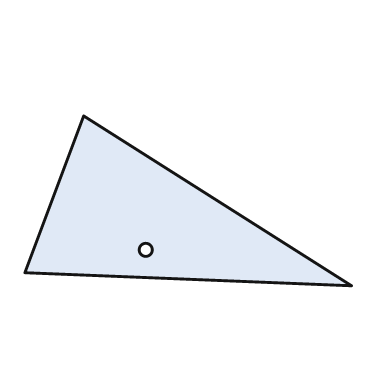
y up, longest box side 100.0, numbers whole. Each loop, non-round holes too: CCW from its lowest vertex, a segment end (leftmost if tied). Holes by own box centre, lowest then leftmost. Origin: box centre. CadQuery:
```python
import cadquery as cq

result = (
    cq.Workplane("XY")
    .moveTo(50.0, -26.0)
    .lineTo(-32.0, 26.0)
    .lineTo(-50.0, -22.0)
    .close()
    .moveTo(-13.0, -15.0)
    .circle(2.0)
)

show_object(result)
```